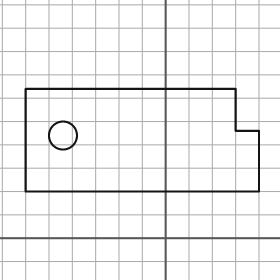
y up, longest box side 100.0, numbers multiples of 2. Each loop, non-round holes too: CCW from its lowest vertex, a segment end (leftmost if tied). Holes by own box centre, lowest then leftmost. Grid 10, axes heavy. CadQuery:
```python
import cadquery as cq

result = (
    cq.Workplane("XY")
    .moveTo(-60.0, 20.0)
    .lineTo(40.0, 20.0)
    .lineTo(40.0, 46.0)
    .lineTo(30.0, 46.0)
    .lineTo(30.0, 64.0)
    .lineTo(-60.0, 64.0)
    .close()
    .moveTo(-44.0, 44.0)
    .circle(6.0)
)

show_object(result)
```